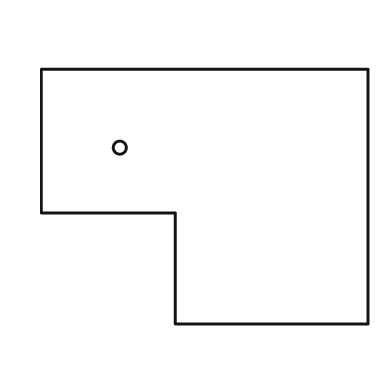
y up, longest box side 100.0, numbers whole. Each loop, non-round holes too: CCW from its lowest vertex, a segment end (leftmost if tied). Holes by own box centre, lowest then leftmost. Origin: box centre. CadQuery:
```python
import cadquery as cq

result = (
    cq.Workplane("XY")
    .moveTo(-9.0, -39.0)
    .lineTo(50.0, -39.0)
    .lineTo(50.0, 39.0)
    .lineTo(-50.0, 39.0)
    .lineTo(-50.0, -5.0)
    .lineTo(-9.0, -5.0)
    .close()
    .moveTo(-26.0, 15.0)
    .circle(2.0)
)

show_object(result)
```